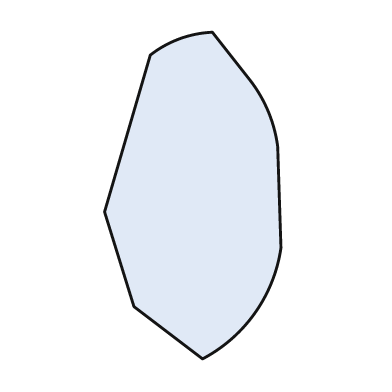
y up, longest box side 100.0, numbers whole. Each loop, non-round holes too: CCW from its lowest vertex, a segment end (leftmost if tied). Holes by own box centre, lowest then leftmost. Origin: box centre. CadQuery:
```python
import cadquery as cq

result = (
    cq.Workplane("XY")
    .moveTo(3.0, -50.0)
    .threePointArc((19.0, -36.0), (27.0, -16.0))
    .lineTo(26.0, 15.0)
    .threePointArc((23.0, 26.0), (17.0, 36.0))
    .lineTo(6.0, 50.0)
    .threePointArc((-4.0, 48.0), (-13.0, 43.0))
    .lineTo(-27.0, -5.0)
    .lineTo(-18.0, -34.0)
    .close()
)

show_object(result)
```